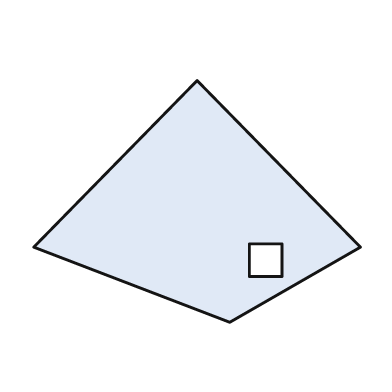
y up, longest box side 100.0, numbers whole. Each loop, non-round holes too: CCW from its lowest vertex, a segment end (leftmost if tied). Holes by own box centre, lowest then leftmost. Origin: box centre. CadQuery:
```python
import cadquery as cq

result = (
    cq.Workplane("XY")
    .moveTo(10.0, -37.0)
    .lineTo(50.0, -14.0)
    .lineTo(0.0, 37.0)
    .lineTo(-50.0, -14.0)
    .close()
    .moveTo(16.0, -23.0)
    .lineTo(26.0, -23.0)
    .lineTo(26.0, -13.0)
    .lineTo(16.0, -13.0)
    .close()
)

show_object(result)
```